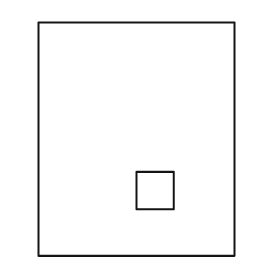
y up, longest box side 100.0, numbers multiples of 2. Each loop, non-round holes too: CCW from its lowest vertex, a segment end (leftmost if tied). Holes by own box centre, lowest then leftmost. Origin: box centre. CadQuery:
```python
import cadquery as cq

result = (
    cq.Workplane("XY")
    .moveTo(-42.0, -50.0)
    .lineTo(42.0, -50.0)
    .lineTo(42.0, 50.0)
    .lineTo(-42.0, 50.0)
    .close()
    .moveTo(0.0, -30.0)
    .lineTo(16.0, -30.0)
    .lineTo(16.0, -14.0)
    .lineTo(0.0, -14.0)
    .close()
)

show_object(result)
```